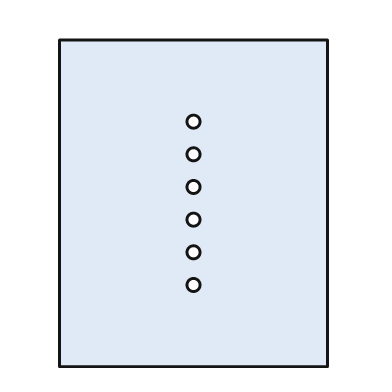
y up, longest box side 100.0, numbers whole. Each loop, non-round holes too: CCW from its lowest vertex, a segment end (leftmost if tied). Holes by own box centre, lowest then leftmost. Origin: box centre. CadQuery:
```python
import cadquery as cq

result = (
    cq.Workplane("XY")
    .moveTo(-41.0, -50.0)
    .lineTo(41.0, -50.0)
    .lineTo(41.0, 50.0)
    .lineTo(-41.0, 50.0)
    .close()
    .moveTo(0.0, -25.0)
    .circle(2.0)
    .moveTo(0.0, -15.0)
    .circle(2.0)
    .moveTo(0.0, -5.0)
    .circle(2.0)
    .moveTo(0.0, 5.0)
    .circle(2.0)
    .moveTo(0.0, 15.0)
    .circle(2.0)
    .moveTo(0.0, 25.0)
    .circle(2.0)
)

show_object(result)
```